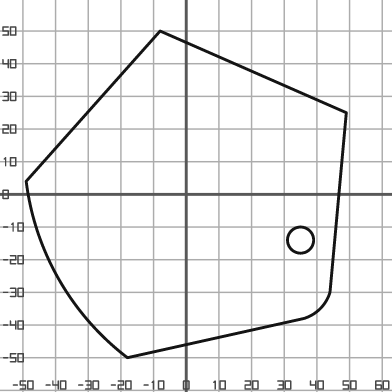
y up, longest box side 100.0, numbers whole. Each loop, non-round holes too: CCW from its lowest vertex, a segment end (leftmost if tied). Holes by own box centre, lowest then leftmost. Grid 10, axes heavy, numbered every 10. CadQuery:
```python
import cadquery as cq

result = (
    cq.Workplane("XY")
    .moveTo(-18.0, -50.0)
    .lineTo(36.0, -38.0)
    .threePointArc((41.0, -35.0), (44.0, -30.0))
    .lineTo(49.0, 25.0)
    .lineTo(-8.0, 50.0)
    .lineTo(-49.0, 4.0)
    .threePointArc((-39.0, -26.0), (-18.0, -50.0))
    .close()
    .moveTo(35.0, -14.0)
    .circle(4.0)
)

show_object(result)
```